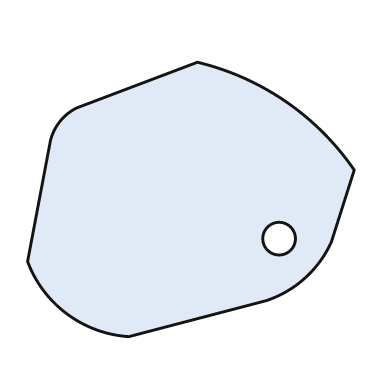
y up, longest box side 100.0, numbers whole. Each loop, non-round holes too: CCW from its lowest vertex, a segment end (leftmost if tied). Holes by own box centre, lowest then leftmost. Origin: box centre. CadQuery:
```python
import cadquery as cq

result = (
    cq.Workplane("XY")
    .moveTo(-19.0, -42.0)
    .lineTo(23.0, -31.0)
    .threePointArc((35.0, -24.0), (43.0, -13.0))
    .lineTo(50.0, 9.0)
    .threePointArc((29.0, 30.0), (2.0, 42.0))
    .lineTo(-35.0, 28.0)
    .threePointArc((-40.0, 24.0), (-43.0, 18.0))
    .lineTo(-50.0, -19.0)
    .threePointArc((-38.0, -35.0), (-19.0, -42.0))
    .close()
    .moveTo(27.0, -12.0)
    .circle(5.0)
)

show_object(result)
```